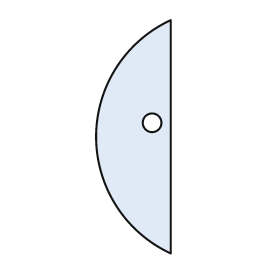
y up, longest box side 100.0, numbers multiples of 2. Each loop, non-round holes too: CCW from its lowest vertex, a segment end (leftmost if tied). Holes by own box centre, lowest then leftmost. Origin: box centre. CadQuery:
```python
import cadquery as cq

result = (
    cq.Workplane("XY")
    .moveTo(16.0, -50.0)
    .lineTo(16.0, 50.0)
    .threePointArc((-16.0, 0.0), (16.0, -50.0))
    .close()
    .moveTo(8.0, 6.0)
    .circle(4.0)
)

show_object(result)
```